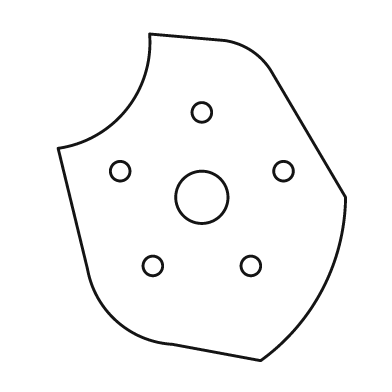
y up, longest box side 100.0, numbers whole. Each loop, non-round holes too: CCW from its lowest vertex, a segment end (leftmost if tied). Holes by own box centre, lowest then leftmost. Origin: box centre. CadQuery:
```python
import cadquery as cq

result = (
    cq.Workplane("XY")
    .moveTo(18.0, -50.0)
    .threePointArc((37.0, -28.0), (44.0, 0.0))
    .lineTo(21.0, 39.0)
    .threePointArc((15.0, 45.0), (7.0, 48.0))
    .lineTo(-16.0, 50.0)
    .threePointArc((-23.0, 27.0), (-44.0, 15.0))
    .lineTo(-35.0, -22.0)
    .threePointArc((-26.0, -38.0), (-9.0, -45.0))
    .close()
    .moveTo(-15.0, -21.0)
    .circle(3.0)
    .moveTo(15.0, -21.0)
    .circle(3.0)
    .moveTo(0.0, 0.0)
    .circle(8.0)
    .moveTo(-25.0, 8.0)
    .circle(3.0)
    .moveTo(25.0, 8.0)
    .circle(3.0)
    .moveTo(0.0, 26.0)
    .circle(3.0)
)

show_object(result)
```